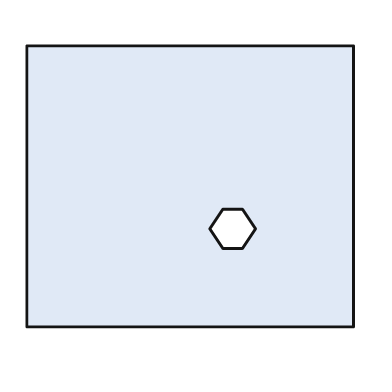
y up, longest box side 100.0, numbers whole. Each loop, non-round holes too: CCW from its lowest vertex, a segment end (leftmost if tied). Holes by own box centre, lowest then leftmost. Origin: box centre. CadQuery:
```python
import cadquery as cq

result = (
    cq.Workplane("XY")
    .moveTo(-50.0, -43.0)
    .lineTo(50.0, -43.0)
    .lineTo(50.0, 43.0)
    .lineTo(-50.0, 43.0)
    .close()
    .moveTo(10.0, -19.0)
    .lineTo(16.0, -19.0)
    .lineTo(20.0, -13.0)
    .lineTo(16.0, -7.0)
    .lineTo(10.0, -7.0)
    .lineTo(6.0, -13.0)
    .close()
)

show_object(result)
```